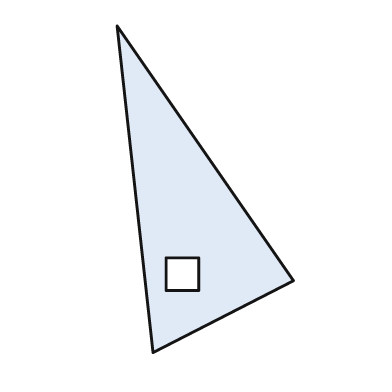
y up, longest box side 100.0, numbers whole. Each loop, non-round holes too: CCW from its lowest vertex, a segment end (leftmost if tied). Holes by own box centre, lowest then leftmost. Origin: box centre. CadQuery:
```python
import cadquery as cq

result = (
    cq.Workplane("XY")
    .moveTo(-16.0, -50.0)
    .lineTo(27.0, -28.0)
    .lineTo(-27.0, 50.0)
    .close()
    .moveTo(-12.0, -31.0)
    .lineTo(-2.0, -31.0)
    .lineTo(-2.0, -21.0)
    .lineTo(-12.0, -21.0)
    .close()
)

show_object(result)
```